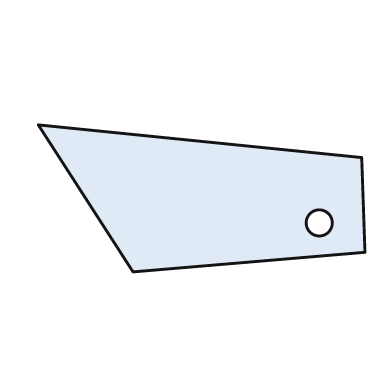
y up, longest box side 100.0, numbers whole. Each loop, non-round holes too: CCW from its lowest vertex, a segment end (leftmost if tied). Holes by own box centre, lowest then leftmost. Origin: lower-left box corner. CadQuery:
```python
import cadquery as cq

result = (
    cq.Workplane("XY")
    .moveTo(29.0, 0.0)
    .lineTo(100.0, 6.0)
    .lineTo(99.0, 35.0)
    .lineTo(0.0, 45.0)
    .close()
    .moveTo(86.0, 15.0)
    .circle(4.0)
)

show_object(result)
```